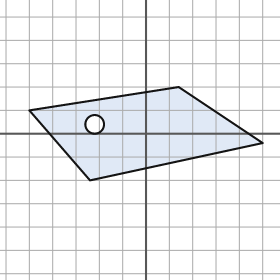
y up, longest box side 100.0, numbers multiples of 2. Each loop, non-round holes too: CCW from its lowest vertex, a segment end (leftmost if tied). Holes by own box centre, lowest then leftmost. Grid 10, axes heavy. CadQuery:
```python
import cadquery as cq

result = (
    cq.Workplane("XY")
    .moveTo(-24.0, -20.0)
    .lineTo(50.0, -4.0)
    .lineTo(14.0, 20.0)
    .lineTo(-50.0, 10.0)
    .close()
    .moveTo(-22.0, 4.0)
    .circle(4.0)
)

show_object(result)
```